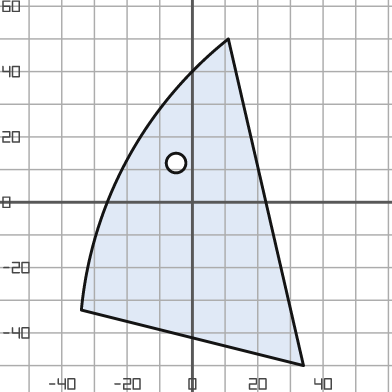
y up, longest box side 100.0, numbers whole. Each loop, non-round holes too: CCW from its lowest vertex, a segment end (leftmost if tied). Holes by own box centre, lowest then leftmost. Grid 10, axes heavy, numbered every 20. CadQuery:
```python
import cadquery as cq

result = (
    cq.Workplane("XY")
    .moveTo(34.0, -50.0)
    .lineTo(11.0, 50.0)
    .threePointArc((-20.0, 13.0), (-34.0, -33.0))
    .close()
    .moveTo(-5.0, 12.0)
    .circle(3.0)
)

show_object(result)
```